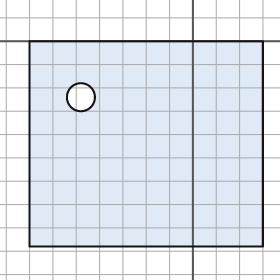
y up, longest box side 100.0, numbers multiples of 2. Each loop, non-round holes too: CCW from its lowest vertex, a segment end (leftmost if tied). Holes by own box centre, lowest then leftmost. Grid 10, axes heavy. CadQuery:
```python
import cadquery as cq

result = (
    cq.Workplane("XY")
    .moveTo(-70.0, -88.0)
    .lineTo(30.0, -88.0)
    .lineTo(30.0, 0.0)
    .lineTo(-70.0, 0.0)
    .close()
    .moveTo(-48.0, -24.0)
    .circle(6.0)
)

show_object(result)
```